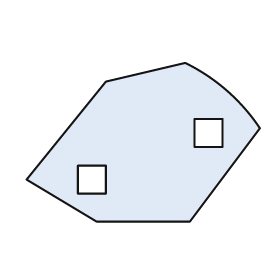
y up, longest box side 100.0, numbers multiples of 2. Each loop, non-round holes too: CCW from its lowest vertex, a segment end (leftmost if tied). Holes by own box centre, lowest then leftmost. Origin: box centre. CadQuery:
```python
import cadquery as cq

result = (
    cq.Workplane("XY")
    .moveTo(-20.0, -34.0)
    .lineTo(20.0, -34.0)
    .lineTo(50.0, 6.0)
    .threePointArc((36.0, 22.0), (18.0, 34.0))
    .lineTo(-16.0, 26.0)
    .lineTo(-50.0, -16.0)
    .close()
    .moveTo(-28.0, -22.0)
    .lineTo(-16.0, -22.0)
    .lineTo(-16.0, -10.0)
    .lineTo(-28.0, -10.0)
    .close()
    .moveTo(22.0, -2.0)
    .lineTo(34.0, -2.0)
    .lineTo(34.0, 10.0)
    .lineTo(22.0, 10.0)
    .close()
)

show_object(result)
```